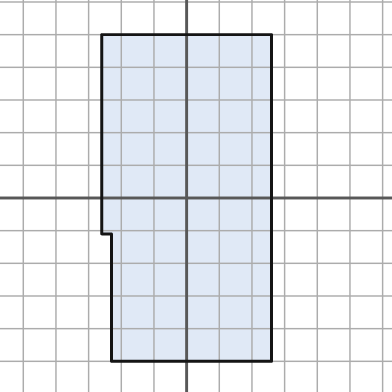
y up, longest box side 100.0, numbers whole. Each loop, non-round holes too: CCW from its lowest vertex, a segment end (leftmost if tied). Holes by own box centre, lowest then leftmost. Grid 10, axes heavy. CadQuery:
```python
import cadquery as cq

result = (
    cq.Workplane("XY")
    .moveTo(-23.0, -50.0)
    .lineTo(26.0, -50.0)
    .lineTo(26.0, 50.0)
    .lineTo(-26.0, 50.0)
    .lineTo(-26.0, -11.0)
    .lineTo(-23.0, -11.0)
    .close()
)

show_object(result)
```